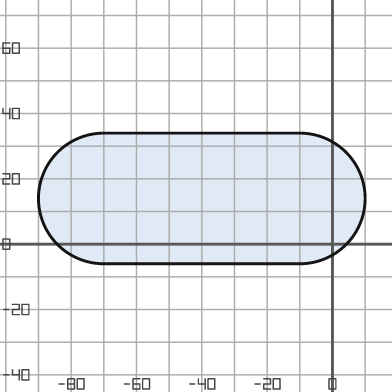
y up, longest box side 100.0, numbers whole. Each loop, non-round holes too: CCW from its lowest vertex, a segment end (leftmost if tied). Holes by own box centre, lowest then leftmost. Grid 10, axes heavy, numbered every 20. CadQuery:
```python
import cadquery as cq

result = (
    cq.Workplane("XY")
    .moveTo(-70.0, -6.0)
    .lineTo(-10.0, -6.0)
    .threePointArc((10.0, 14.0), (-10.0, 34.0))
    .lineTo(-70.0, 34.0)
    .threePointArc((-90.0, 14.0), (-70.0, -6.0))
    .close()
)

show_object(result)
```